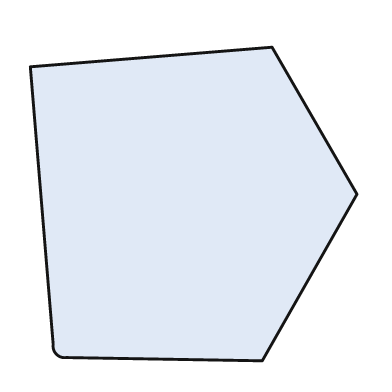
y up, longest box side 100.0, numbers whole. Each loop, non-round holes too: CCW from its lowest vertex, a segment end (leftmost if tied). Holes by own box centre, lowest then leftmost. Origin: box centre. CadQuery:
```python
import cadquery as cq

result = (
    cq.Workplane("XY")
    .moveTo(21.0, -48.0)
    .lineTo(50.0, 3.0)
    .lineTo(24.0, 48.0)
    .lineTo(-50.0, 42.0)
    .lineTo(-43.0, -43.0)
    .threePointArc((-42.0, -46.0), (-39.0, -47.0))
    .close()
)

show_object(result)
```